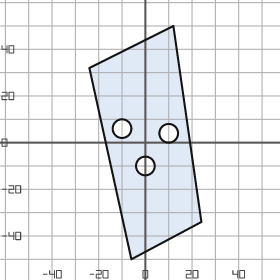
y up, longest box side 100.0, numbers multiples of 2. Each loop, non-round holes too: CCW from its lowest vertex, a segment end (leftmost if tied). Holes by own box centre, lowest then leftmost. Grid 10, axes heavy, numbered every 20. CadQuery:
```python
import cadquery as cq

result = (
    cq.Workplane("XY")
    .moveTo(-6.0, -50.0)
    .lineTo(24.0, -34.0)
    .lineTo(12.0, 50.0)
    .lineTo(-24.0, 32.0)
    .close()
    .moveTo(0.0, -10.0)
    .circle(4.0)
    .moveTo(10.0, 4.0)
    .circle(4.0)
    .moveTo(-10.0, 6.0)
    .circle(4.0)
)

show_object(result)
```